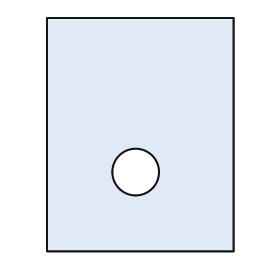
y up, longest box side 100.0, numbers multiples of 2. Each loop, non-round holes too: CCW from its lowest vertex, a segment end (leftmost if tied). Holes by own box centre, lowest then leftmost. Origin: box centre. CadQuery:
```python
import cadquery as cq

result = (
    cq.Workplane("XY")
    .moveTo(-40.0, -50.0)
    .lineTo(40.0, -50.0)
    .lineTo(40.0, 50.0)
    .lineTo(-40.0, 50.0)
    .close()
    .moveTo(-2.0, -16.0)
    .circle(10.0)
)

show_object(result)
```